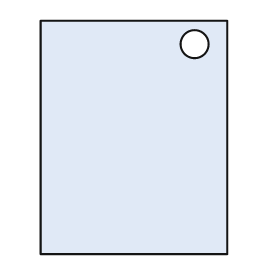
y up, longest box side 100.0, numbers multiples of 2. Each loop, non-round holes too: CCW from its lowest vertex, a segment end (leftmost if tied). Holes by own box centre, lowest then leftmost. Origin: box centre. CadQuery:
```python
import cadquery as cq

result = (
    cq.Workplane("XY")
    .moveTo(-40.0, -50.0)
    .lineTo(40.0, -50.0)
    .lineTo(40.0, 50.0)
    .lineTo(-40.0, 50.0)
    .close()
    .moveTo(26.0, 40.0)
    .circle(6.0)
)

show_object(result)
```